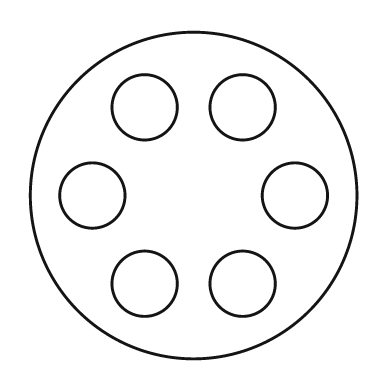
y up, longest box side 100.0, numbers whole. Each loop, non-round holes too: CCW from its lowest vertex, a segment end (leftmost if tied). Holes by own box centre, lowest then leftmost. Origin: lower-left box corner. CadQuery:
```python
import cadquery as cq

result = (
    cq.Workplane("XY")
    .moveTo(50.0, 50.0)
    .circle(50.0)
    .moveTo(35.0, 23.0)
    .circle(10.0)
    .moveTo(65.0, 23.0)
    .circle(10.0)
    .moveTo(19.0, 50.0)
    .circle(10.0)
    .moveTo(81.0, 50.0)
    .circle(10.0)
    .moveTo(35.0, 77.0)
    .circle(10.0)
    .moveTo(65.0, 77.0)
    .circle(10.0)
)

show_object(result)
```